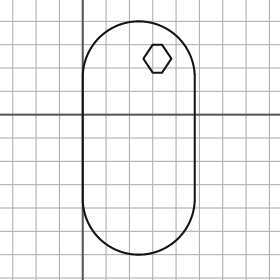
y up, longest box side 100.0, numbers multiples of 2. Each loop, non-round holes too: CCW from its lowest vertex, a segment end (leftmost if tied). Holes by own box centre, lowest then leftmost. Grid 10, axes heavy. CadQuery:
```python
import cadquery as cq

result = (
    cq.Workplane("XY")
    .moveTo(0.0, -36.0)
    .threePointArc((24.0, -60.0), (48.0, -36.0))
    .lineTo(48.0, 16.0)
    .threePointArc((24.0, 40.0), (0.0, 16.0))
    .close()
    .moveTo(30.0, 18.0)
    .lineTo(34.0, 18.0)
    .lineTo(38.0, 24.0)
    .lineTo(34.0, 30.0)
    .lineTo(30.0, 30.0)
    .lineTo(26.0, 24.0)
    .close()
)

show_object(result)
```